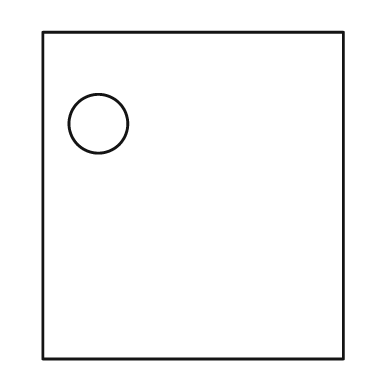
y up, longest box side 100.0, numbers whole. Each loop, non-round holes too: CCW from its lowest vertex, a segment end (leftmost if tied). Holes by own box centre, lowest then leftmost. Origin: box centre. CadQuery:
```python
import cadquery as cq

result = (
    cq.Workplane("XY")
    .moveTo(-46.0, -50.0)
    .lineTo(46.0, -50.0)
    .lineTo(46.0, 50.0)
    .lineTo(-46.0, 50.0)
    .close()
    .moveTo(-29.0, 22.0)
    .circle(9.0)
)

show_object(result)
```